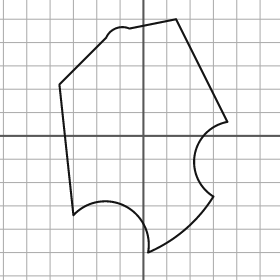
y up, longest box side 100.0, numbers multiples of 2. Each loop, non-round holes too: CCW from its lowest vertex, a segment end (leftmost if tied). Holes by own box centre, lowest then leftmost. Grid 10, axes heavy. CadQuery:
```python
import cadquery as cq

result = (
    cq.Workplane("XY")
    .moveTo(2.0, -50.0)
    .threePointArc((18.0, -40.0), (30.0, -26.0))
    .threePointArc((22.0, -8.0), (36.0, 6.0))
    .lineTo(14.0, 50.0)
    .lineTo(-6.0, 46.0)
    .threePointArc((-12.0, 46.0), (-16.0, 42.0))
    .lineTo(-36.0, 22.0)
    .lineTo(-30.0, -34.0)
    .threePointArc((-8.0, -30.0), (2.0, -50.0))
    .close()
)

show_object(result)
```